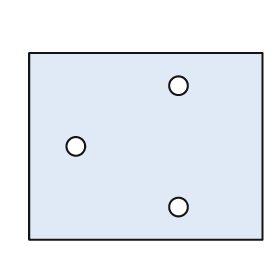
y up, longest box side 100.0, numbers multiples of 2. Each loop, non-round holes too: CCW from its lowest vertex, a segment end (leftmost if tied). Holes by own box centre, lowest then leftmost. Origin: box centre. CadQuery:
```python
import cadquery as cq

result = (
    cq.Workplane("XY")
    .moveTo(-50.0, -40.0)
    .lineTo(50.0, -40.0)
    .lineTo(50.0, 40.0)
    .lineTo(-50.0, 40.0)
    .close()
    .moveTo(14.0, -26.0)
    .circle(4.0)
    .moveTo(-30.0, 0.0)
    .circle(4.0)
    .moveTo(14.0, 26.0)
    .circle(4.0)
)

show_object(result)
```